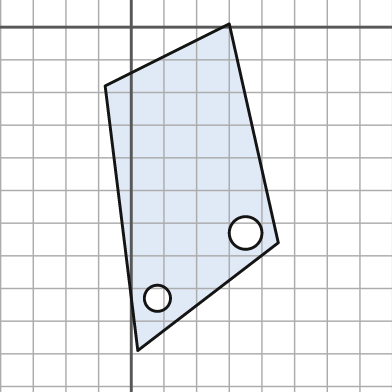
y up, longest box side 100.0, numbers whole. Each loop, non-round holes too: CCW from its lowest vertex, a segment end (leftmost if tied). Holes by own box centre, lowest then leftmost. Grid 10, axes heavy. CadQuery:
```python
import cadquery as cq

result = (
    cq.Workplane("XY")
    .moveTo(2.0, -99.0)
    .lineTo(45.0, -66.0)
    .lineTo(30.0, 1.0)
    .lineTo(-8.0, -18.0)
    .close()
    .moveTo(8.0, -83.0)
    .circle(4.0)
    .moveTo(35.0, -63.0)
    .circle(5.0)
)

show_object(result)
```